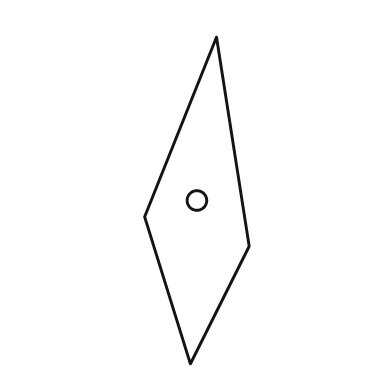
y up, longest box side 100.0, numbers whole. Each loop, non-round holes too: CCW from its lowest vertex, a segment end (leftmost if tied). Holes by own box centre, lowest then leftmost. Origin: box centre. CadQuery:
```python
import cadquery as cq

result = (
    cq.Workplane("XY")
    .moveTo(-2.0, -50.0)
    .lineTo(16.0, -14.0)
    .lineTo(6.0, 50.0)
    .lineTo(-16.0, -5.0)
    .close()
    .moveTo(0.0, 0.0)
    .circle(3.0)
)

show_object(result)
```